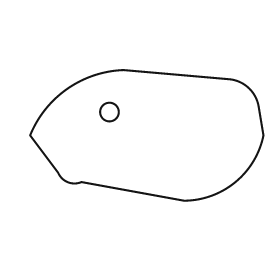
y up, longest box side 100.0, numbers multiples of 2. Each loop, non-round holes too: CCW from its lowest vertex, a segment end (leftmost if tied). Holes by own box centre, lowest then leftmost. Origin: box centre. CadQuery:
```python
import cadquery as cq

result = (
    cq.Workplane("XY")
    .moveTo(16.0, -28.0)
    .threePointArc((38.0, -20.0), (50.0, 0.0))
    .lineTo(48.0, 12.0)
    .threePointArc((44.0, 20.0), (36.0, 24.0))
    .lineTo(-10.0, 28.0)
    .threePointArc((-34.0, 20.0), (-50.0, 0.0))
    .lineTo(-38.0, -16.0)
    .threePointArc((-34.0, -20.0), (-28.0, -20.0))
    .close()
    .moveTo(-16.0, 10.0)
    .circle(4.0)
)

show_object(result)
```